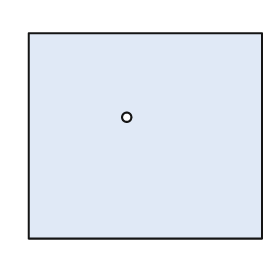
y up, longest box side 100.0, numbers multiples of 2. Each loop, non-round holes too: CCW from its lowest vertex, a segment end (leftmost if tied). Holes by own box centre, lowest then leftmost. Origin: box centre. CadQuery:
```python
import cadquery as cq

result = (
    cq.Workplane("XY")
    .moveTo(-50.0, -44.0)
    .lineTo(50.0, -44.0)
    .lineTo(50.0, 44.0)
    .lineTo(-50.0, 44.0)
    .close()
    .moveTo(-8.0, 8.0)
    .circle(2.0)
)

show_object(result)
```